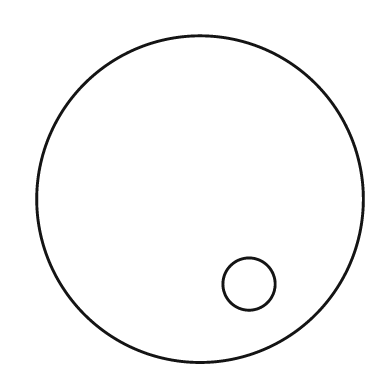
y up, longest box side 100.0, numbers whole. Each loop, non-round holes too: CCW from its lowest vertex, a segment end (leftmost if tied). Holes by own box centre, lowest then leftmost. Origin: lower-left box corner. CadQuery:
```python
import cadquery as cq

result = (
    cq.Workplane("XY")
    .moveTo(50.0, 50.0)
    .circle(50.0)
    .moveTo(65.0, 24.0)
    .circle(8.0)
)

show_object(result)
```